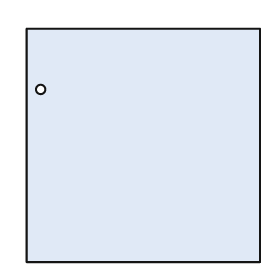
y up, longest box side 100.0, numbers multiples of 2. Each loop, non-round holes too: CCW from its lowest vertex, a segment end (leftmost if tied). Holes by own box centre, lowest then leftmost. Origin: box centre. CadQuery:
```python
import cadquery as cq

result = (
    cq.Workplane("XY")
    .moveTo(-50.0, -50.0)
    .lineTo(50.0, -50.0)
    .lineTo(50.0, 50.0)
    .lineTo(-50.0, 50.0)
    .close()
    .moveTo(-44.0, 24.0)
    .circle(2.0)
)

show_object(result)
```